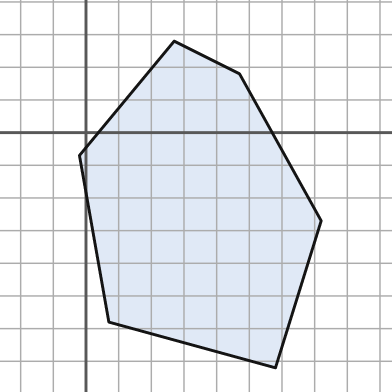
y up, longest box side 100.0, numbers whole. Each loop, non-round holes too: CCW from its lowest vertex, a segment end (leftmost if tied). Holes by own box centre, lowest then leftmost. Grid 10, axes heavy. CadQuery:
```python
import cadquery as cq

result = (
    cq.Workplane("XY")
    .moveTo(58.0, -72.0)
    .lineTo(72.0, -27.0)
    .lineTo(47.0, 18.0)
    .lineTo(27.0, 28.0)
    .lineTo(-2.0, -7.0)
    .lineTo(7.0, -58.0)
    .close()
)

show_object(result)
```